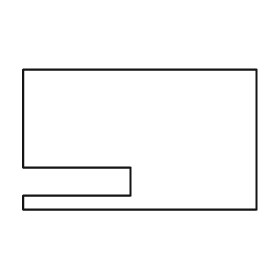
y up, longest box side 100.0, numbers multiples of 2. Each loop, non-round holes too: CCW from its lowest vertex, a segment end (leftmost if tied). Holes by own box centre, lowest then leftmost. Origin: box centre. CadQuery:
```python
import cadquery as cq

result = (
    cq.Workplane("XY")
    .moveTo(-50.0, -30.0)
    .lineTo(50.0, -30.0)
    .lineTo(50.0, 30.0)
    .lineTo(-50.0, 30.0)
    .lineTo(-50.0, -12.0)
    .lineTo(-4.0, -12.0)
    .lineTo(-4.0, -24.0)
    .lineTo(-50.0, -24.0)
    .close()
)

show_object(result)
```